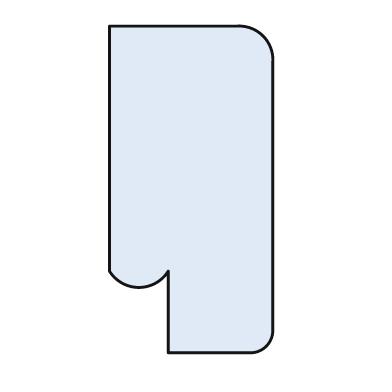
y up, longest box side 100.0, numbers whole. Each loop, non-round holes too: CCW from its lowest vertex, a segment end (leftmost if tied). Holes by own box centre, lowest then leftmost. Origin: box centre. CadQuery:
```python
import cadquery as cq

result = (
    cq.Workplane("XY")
    .moveTo(-7.0, -50.0)
    .lineTo(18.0, -50.0)
    .threePointArc((23.0, -48.0), (25.0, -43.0))
    .lineTo(25.0, 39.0)
    .threePointArc((22.0, 47.0), (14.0, 50.0))
    .lineTo(-25.0, 50.0)
    .lineTo(-25.0, -25.0)
    .threePointArc((-16.0, -30.0), (-7.0, -25.0))
    .close()
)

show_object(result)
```